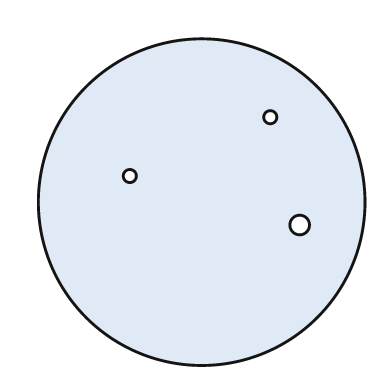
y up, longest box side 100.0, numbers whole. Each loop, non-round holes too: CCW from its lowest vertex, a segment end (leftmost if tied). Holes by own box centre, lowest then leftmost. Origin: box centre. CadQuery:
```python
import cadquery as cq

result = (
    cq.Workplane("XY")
    .moveTo(0.0, 0.0)
    .circle(50.0)
    .moveTo(30.0, -7.0)
    .circle(3.0)
    .moveTo(-22.0, 8.0)
    .circle(2.0)
    .moveTo(21.0, 26.0)
    .circle(2.0)
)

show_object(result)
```